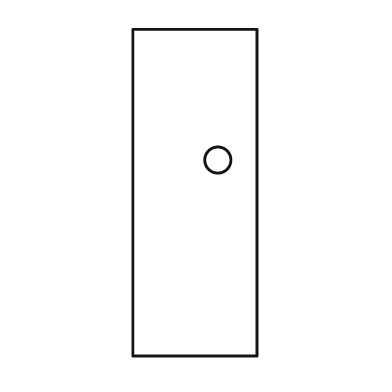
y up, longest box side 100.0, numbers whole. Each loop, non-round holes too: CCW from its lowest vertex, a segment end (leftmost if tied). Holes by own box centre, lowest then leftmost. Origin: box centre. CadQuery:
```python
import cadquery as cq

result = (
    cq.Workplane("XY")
    .moveTo(-19.0, -50.0)
    .lineTo(19.0, -50.0)
    .lineTo(19.0, 50.0)
    .lineTo(-19.0, 50.0)
    .close()
    .moveTo(7.0, 10.0)
    .circle(4.0)
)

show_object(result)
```